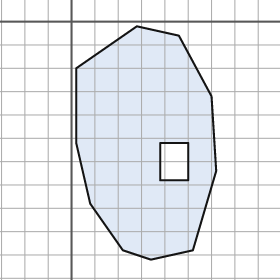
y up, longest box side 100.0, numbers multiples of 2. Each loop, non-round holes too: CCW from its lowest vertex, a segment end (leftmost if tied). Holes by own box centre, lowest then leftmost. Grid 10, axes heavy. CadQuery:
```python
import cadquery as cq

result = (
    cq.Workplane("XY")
    .moveTo(34.0, -102.0)
    .lineTo(52.0, -98.0)
    .lineTo(62.0, -64.0)
    .lineTo(60.0, -32.0)
    .lineTo(46.0, -6.0)
    .lineTo(28.0, -2.0)
    .lineTo(2.0, -20.0)
    .lineTo(2.0, -52.0)
    .lineTo(8.0, -78.0)
    .lineTo(22.0, -98.0)
    .close()
    .moveTo(38.0, -68.0)
    .lineTo(50.0, -68.0)
    .lineTo(50.0, -52.0)
    .lineTo(38.0, -52.0)
    .close()
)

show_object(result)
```